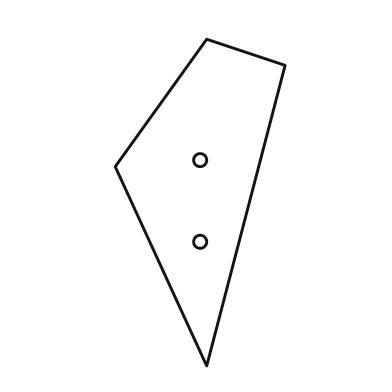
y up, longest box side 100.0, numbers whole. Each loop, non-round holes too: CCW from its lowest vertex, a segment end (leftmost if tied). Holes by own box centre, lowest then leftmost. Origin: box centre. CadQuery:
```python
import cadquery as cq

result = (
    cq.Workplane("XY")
    .moveTo(2.0, -50.0)
    .lineTo(26.0, 42.0)
    .lineTo(2.0, 50.0)
    .lineTo(-26.0, 11.0)
    .close()
    .moveTo(0.0, -12.0)
    .circle(2.0)
    .moveTo(0.0, 13.0)
    .circle(2.0)
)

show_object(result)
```